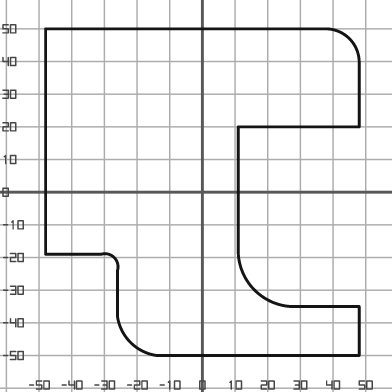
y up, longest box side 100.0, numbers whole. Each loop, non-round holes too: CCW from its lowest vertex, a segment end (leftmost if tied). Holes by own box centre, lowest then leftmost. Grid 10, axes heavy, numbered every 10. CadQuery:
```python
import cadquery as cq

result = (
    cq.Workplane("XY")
    .moveTo(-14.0, -50.0)
    .lineTo(48.0, -50.0)
    .lineTo(48.0, -35.0)
    .lineTo(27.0, -35.0)
    .threePointArc((16.0, -30.0), (11.0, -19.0))
    .lineTo(11.0, 20.0)
    .lineTo(48.0, 20.0)
    .lineTo(48.0, 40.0)
    .threePointArc((45.0, 47.0), (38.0, 50.0))
    .lineTo(-48.0, 50.0)
    .lineTo(-48.0, -19.0)
    .lineTo(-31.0, -19.0)
    .threePointArc((-27.0, -20.0), (-26.0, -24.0))
    .lineTo(-26.0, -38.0)
    .threePointArc((-22.0, -46.0), (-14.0, -50.0))
    .close()
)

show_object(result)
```